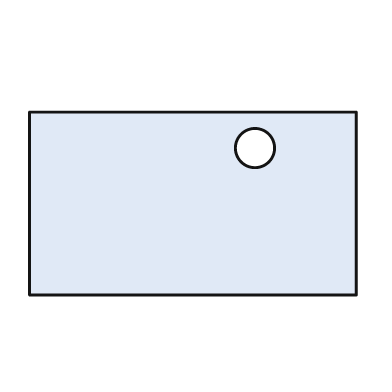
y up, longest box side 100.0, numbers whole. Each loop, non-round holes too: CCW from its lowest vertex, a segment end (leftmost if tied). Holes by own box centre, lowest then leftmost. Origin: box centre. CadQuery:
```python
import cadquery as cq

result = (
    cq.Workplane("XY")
    .moveTo(-50.0, -28.0)
    .lineTo(50.0, -28.0)
    .lineTo(50.0, 28.0)
    .lineTo(-50.0, 28.0)
    .close()
    .moveTo(19.0, 17.0)
    .circle(6.0)
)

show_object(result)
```